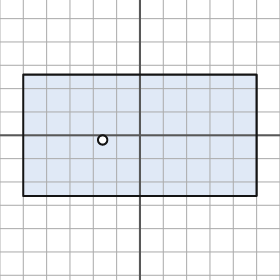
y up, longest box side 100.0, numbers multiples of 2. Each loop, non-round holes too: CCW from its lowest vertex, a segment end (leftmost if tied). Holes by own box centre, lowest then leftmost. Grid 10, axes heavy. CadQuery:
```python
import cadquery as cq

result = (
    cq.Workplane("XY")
    .moveTo(-50.0, -26.0)
    .lineTo(50.0, -26.0)
    .lineTo(50.0, 26.0)
    .lineTo(-50.0, 26.0)
    .close()
    .moveTo(-16.0, -2.0)
    .circle(2.0)
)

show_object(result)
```